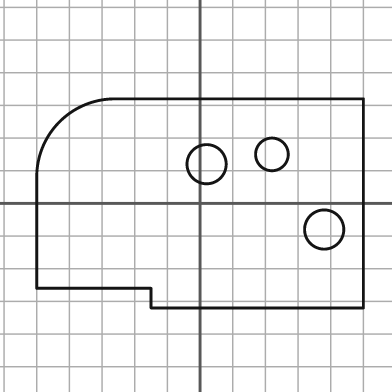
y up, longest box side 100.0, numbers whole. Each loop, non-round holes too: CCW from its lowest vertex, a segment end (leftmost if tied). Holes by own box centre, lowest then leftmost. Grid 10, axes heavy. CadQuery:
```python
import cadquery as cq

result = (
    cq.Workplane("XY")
    .moveTo(-15.0, -32.0)
    .lineTo(50.0, -32.0)
    .lineTo(50.0, 32.0)
    .lineTo(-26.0, 32.0)
    .threePointArc((-43.0, 25.0), (-50.0, 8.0))
    .lineTo(-50.0, -26.0)
    .lineTo(-15.0, -26.0)
    .close()
    .moveTo(38.0, -8.0)
    .circle(6.0)
    .moveTo(2.0, 12.0)
    .circle(6.0)
    .moveTo(22.0, 15.0)
    .circle(5.0)
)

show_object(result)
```